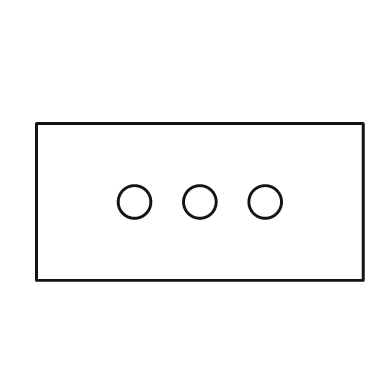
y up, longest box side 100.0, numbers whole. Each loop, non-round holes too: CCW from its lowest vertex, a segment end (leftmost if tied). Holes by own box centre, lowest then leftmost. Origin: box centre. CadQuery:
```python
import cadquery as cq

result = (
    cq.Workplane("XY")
    .moveTo(-50.0, -24.0)
    .lineTo(50.0, -24.0)
    .lineTo(50.0, 24.0)
    .lineTo(-50.0, 24.0)
    .close()
    .moveTo(-20.0, 0.0)
    .circle(5.0)
    .moveTo(0.0, 0.0)
    .circle(5.0)
    .moveTo(20.0, 0.0)
    .circle(5.0)
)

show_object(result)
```